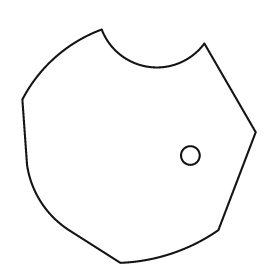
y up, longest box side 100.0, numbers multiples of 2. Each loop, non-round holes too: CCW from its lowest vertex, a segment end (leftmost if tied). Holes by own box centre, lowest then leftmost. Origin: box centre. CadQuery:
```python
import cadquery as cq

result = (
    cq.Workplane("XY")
    .moveTo(-8.0, -50.0)
    .threePointArc((14.0, -46.0), (34.0, -36.0))
    .lineTo(50.0, 6.0)
    .lineTo(28.0, 44.0)
    .threePointArc((4.0, 34.0), (-16.0, 50.0))
    .threePointArc((-36.0, 38.0), (-50.0, 20.0))
    .lineTo(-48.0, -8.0)
    .threePointArc((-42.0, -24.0), (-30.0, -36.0))
    .close()
    .moveTo(22.0, -4.0)
    .circle(4.0)
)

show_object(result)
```